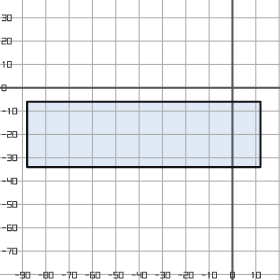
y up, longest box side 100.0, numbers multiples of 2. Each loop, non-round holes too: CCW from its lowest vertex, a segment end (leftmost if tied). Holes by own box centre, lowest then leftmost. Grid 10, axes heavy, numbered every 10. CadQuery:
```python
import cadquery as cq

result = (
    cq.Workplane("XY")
    .moveTo(-88.0, -34.0)
    .lineTo(12.0, -34.0)
    .lineTo(12.0, -6.0)
    .lineTo(-88.0, -6.0)
    .close()
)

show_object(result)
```